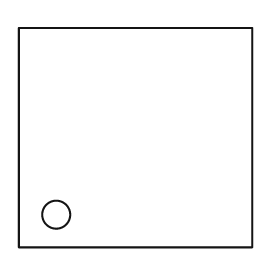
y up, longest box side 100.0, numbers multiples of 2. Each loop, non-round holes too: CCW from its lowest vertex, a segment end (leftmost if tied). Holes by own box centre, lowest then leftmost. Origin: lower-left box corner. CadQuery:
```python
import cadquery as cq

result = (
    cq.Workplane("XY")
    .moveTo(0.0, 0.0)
    .lineTo(100.0, 0.0)
    .lineTo(100.0, 94.0)
    .lineTo(0.0, 94.0)
    .close()
    .moveTo(16.0, 14.0)
    .circle(6.0)
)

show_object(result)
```